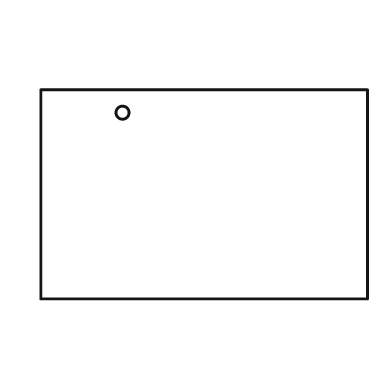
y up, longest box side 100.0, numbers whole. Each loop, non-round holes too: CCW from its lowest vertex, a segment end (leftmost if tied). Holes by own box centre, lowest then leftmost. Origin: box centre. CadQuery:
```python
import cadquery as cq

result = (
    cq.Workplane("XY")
    .moveTo(-50.0, -32.0)
    .lineTo(50.0, -32.0)
    .lineTo(50.0, 32.0)
    .lineTo(-50.0, 32.0)
    .close()
    .moveTo(-25.0, 25.0)
    .circle(2.0)
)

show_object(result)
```